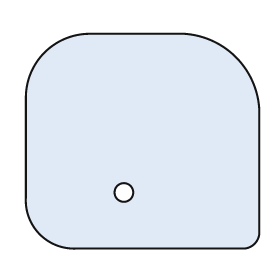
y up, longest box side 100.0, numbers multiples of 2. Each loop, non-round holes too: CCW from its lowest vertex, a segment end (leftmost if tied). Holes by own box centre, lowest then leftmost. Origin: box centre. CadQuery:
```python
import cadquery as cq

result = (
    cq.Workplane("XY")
    .moveTo(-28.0, -46.0)
    .lineTo(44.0, -46.0)
    .threePointArc((48.0, -44.0), (50.0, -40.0))
    .lineTo(50.0, 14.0)
    .threePointArc((40.0, 36.0), (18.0, 46.0))
    .lineTo(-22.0, 46.0)
    .threePointArc((-42.0, 38.0), (-50.0, 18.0))
    .lineTo(-50.0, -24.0)
    .threePointArc((-44.0, -40.0), (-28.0, -46.0))
    .close()
    .moveTo(-8.0, -22.0)
    .circle(4.0)
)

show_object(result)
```